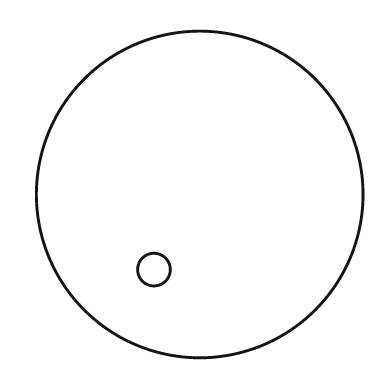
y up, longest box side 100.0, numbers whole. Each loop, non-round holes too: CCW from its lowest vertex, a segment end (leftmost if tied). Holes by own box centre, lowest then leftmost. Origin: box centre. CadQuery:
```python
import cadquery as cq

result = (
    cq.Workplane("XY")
    .moveTo(0.0, 0.0)
    .circle(50.0)
    .moveTo(-14.0, -23.0)
    .circle(5.0)
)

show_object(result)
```